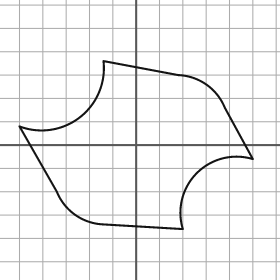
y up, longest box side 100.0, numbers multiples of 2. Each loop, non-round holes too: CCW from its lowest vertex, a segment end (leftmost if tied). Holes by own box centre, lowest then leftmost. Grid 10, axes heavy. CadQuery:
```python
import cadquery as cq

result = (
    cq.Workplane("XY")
    .moveTo(20.0, -36.0)
    .threePointArc((26.0, -12.0), (50.0, -6.0))
    .lineTo(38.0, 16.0)
    .threePointArc((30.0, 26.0), (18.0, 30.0))
    .lineTo(-14.0, 36.0)
    .threePointArc((-24.0, 12.0), (-50.0, 8.0))
    .lineTo(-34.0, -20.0)
    .threePointArc((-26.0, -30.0), (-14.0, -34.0))
    .close()
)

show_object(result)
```